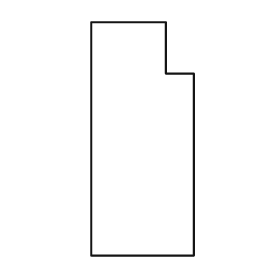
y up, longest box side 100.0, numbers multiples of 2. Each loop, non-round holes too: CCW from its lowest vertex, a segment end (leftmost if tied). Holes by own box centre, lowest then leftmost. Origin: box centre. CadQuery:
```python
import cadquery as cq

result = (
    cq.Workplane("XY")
    .moveTo(-22.0, -50.0)
    .lineTo(22.0, -50.0)
    .lineTo(22.0, 28.0)
    .lineTo(10.0, 28.0)
    .lineTo(10.0, 50.0)
    .lineTo(-22.0, 50.0)
    .close()
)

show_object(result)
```